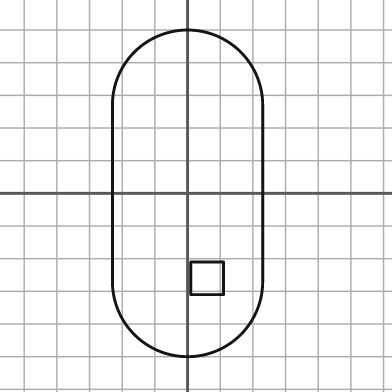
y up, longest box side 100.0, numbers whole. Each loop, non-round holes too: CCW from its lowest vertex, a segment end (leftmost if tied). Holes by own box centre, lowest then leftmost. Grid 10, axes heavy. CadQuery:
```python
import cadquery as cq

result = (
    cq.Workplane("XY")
    .moveTo(-23.0, -27.0)
    .threePointArc((0.0, -50.0), (23.0, -27.0))
    .lineTo(23.0, 27.0)
    .threePointArc((0.0, 50.0), (-23.0, 27.0))
    .close()
    .moveTo(1.0, -31.0)
    .lineTo(11.0, -31.0)
    .lineTo(11.0, -21.0)
    .lineTo(1.0, -21.0)
    .close()
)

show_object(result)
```